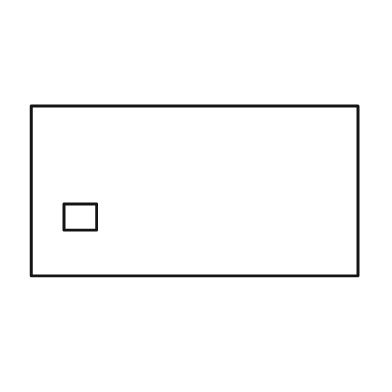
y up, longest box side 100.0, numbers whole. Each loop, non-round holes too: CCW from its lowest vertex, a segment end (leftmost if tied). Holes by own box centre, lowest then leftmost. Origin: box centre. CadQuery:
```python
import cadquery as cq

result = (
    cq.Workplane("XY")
    .moveTo(-50.0, -26.0)
    .lineTo(50.0, -26.0)
    .lineTo(50.0, 26.0)
    .lineTo(-50.0, 26.0)
    .close()
    .moveTo(-40.0, -12.0)
    .lineTo(-30.0, -12.0)
    .lineTo(-30.0, -4.0)
    .lineTo(-40.0, -4.0)
    .close()
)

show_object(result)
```